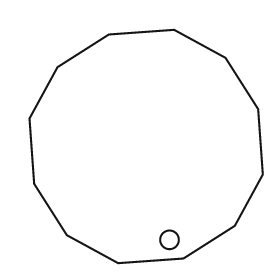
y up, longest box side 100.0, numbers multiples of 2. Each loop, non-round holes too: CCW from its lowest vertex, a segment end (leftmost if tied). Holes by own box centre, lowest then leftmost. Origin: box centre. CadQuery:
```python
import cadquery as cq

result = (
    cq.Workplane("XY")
    .moveTo(-12.0, -50.0)
    .lineTo(16.0, -48.0)
    .lineTo(38.0, -34.0)
    .lineTo(50.0, -12.0)
    .lineTo(48.0, 16.0)
    .lineTo(34.0, 38.0)
    .lineTo(12.0, 50.0)
    .lineTo(-16.0, 48.0)
    .lineTo(-38.0, 34.0)
    .lineTo(-50.0, 12.0)
    .lineTo(-48.0, -16.0)
    .lineTo(-34.0, -38.0)
    .close()
    .moveTo(10.0, -40.0)
    .circle(4.0)
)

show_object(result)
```